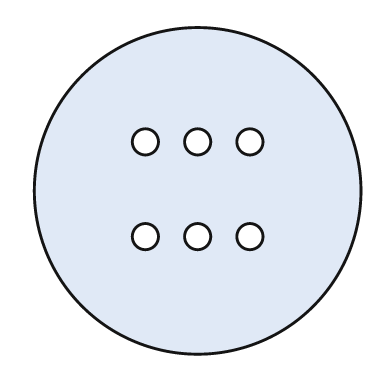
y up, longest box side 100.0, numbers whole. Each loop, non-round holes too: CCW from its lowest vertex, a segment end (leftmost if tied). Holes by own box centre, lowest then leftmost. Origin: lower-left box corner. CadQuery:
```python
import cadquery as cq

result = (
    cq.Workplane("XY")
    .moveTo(50.0, 50.0)
    .circle(50.0)
    .moveTo(34.0, 36.0)
    .circle(4.0)
    .moveTo(50.0, 36.0)
    .circle(4.0)
    .moveTo(66.0, 36.0)
    .circle(4.0)
    .moveTo(34.0, 65.0)
    .circle(4.0)
    .moveTo(50.0, 65.0)
    .circle(4.0)
    .moveTo(66.0, 65.0)
    .circle(4.0)
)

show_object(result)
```